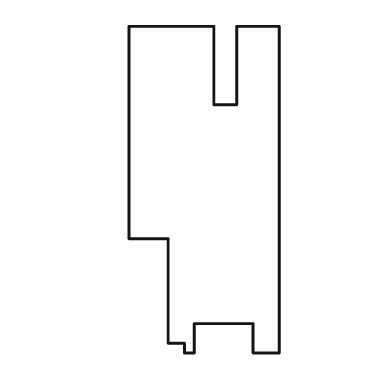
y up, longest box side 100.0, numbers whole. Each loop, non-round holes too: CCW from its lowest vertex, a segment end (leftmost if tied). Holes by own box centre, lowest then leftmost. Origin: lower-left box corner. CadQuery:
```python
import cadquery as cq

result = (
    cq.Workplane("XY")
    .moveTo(17.0, 0.0)
    .lineTo(20.0, 0.0)
    .lineTo(20.0, 9.0)
    .lineTo(38.0, 9.0)
    .lineTo(38.0, 0.0)
    .lineTo(46.0, 0.0)
    .lineTo(46.0, 100.0)
    .lineTo(33.0, 100.0)
    .lineTo(33.0, 76.0)
    .lineTo(26.0, 76.0)
    .lineTo(26.0, 100.0)
    .lineTo(0.0, 100.0)
    .lineTo(0.0, 35.0)
    .lineTo(12.0, 35.0)
    .lineTo(12.0, 3.0)
    .lineTo(17.0, 3.0)
    .close()
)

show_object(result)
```